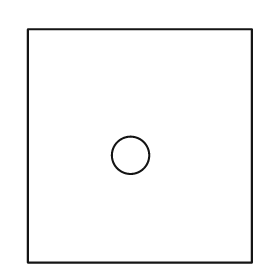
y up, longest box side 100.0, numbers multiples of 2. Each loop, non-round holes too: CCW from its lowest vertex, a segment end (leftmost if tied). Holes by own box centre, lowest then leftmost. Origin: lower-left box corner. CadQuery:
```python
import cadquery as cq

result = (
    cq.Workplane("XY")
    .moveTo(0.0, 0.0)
    .lineTo(96.0, 0.0)
    .lineTo(96.0, 100.0)
    .lineTo(0.0, 100.0)
    .close()
    .moveTo(44.0, 46.0)
    .circle(8.0)
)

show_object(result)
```